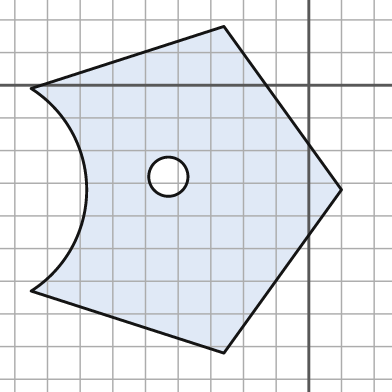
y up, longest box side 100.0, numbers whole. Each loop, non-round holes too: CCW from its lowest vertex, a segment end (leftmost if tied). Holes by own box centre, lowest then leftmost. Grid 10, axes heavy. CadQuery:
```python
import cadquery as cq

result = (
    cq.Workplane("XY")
    .moveTo(-26.0, -82.0)
    .lineTo(10.0, -32.0)
    .lineTo(-26.0, 18.0)
    .lineTo(-85.0, -1.0)
    .threePointArc((-68.0, -32.0), (-85.0, -63.0))
    .close()
    .moveTo(-43.0, -28.0)
    .circle(6.0)
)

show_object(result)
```